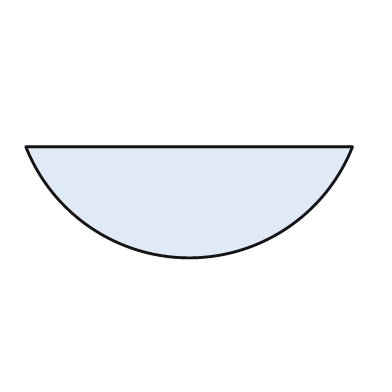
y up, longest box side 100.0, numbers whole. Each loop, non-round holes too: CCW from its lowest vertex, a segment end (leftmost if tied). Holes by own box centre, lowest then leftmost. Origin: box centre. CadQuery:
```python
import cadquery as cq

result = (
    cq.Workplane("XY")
    .moveTo(-50.0, 17.0)
    .threePointArc((0.0, -17.0), (50.0, 17.0))
    .close()
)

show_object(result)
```